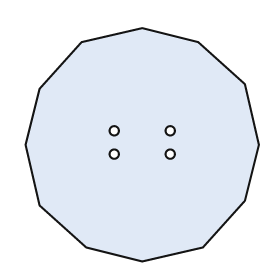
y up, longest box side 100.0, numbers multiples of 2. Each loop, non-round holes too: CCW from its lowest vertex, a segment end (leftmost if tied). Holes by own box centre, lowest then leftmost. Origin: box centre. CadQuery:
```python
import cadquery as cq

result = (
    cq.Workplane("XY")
    .moveTo(0.0, -50.0)
    .lineTo(26.0, -44.0)
    .lineTo(44.0, -24.0)
    .lineTo(50.0, 0.0)
    .lineTo(44.0, 26.0)
    .lineTo(24.0, 44.0)
    .lineTo(0.0, 50.0)
    .lineTo(-26.0, 44.0)
    .lineTo(-44.0, 24.0)
    .lineTo(-50.0, 0.0)
    .lineTo(-44.0, -26.0)
    .lineTo(-24.0, -44.0)
    .close()
    .moveTo(-12.0, -4.0)
    .circle(2.0)
    .moveTo(12.0, -4.0)
    .circle(2.0)
    .moveTo(-12.0, 6.0)
    .circle(2.0)
    .moveTo(12.0, 6.0)
    .circle(2.0)
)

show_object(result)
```